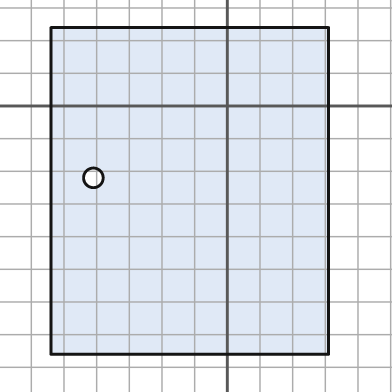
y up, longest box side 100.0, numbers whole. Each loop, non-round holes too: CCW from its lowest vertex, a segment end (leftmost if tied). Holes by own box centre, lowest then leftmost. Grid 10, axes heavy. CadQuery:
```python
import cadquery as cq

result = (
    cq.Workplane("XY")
    .moveTo(-54.0, -76.0)
    .lineTo(31.0, -76.0)
    .lineTo(31.0, 24.0)
    .lineTo(-54.0, 24.0)
    .close()
    .moveTo(-41.0, -22.0)
    .circle(3.0)
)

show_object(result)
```